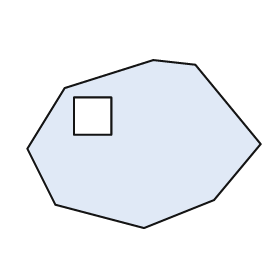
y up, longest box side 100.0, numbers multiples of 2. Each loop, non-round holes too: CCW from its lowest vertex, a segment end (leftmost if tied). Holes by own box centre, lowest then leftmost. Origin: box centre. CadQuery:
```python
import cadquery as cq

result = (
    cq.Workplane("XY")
    .moveTo(0.0, -36.0)
    .lineTo(30.0, -24.0)
    .lineTo(50.0, 0.0)
    .lineTo(22.0, 34.0)
    .lineTo(4.0, 36.0)
    .lineTo(-34.0, 24.0)
    .lineTo(-50.0, -2.0)
    .lineTo(-38.0, -26.0)
    .close()
    .moveTo(-30.0, 4.0)
    .lineTo(-14.0, 4.0)
    .lineTo(-14.0, 20.0)
    .lineTo(-30.0, 20.0)
    .close()
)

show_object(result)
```